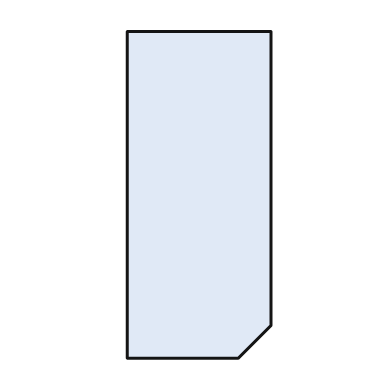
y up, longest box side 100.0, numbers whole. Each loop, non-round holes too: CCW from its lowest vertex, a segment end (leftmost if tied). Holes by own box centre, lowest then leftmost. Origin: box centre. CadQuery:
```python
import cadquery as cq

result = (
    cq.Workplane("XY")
    .moveTo(-22.0, -50.0)
    .lineTo(12.0, -50.0)
    .lineTo(22.0, -40.0)
    .lineTo(22.0, 50.0)
    .lineTo(-22.0, 50.0)
    .close()
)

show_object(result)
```